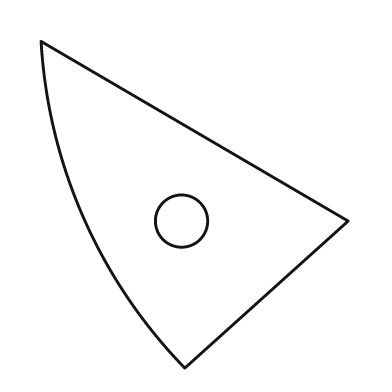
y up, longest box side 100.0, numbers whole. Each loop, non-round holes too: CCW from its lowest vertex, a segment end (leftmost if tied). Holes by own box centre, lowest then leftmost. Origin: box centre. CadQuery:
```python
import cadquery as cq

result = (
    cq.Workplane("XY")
    .moveTo(-3.0, -50.0)
    .lineTo(47.0, -5.0)
    .lineTo(-47.0, 50.0)
    .threePointArc((-34.0, -4.0), (-3.0, -50.0))
    .close()
    .moveTo(-4.0, -5.0)
    .circle(8.0)
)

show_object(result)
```